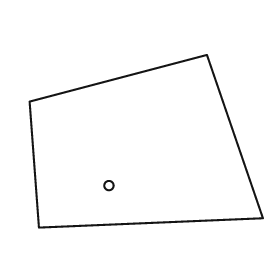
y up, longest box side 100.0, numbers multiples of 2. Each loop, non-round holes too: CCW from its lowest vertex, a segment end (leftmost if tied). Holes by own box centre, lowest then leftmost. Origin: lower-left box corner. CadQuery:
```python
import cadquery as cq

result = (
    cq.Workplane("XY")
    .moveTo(4.0, 0.0)
    .lineTo(100.0, 4.0)
    .lineTo(76.0, 74.0)
    .lineTo(0.0, 54.0)
    .close()
    .moveTo(34.0, 18.0)
    .circle(2.0)
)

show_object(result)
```